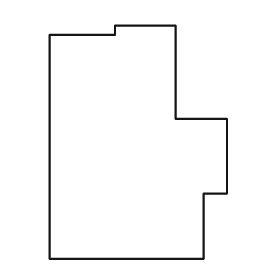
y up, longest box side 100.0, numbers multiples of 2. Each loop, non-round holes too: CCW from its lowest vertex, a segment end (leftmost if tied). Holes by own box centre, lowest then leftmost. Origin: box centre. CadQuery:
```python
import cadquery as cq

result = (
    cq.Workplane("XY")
    .moveTo(-38.0, -50.0)
    .lineTo(28.0, -50.0)
    .lineTo(28.0, -22.0)
    .lineTo(38.0, -22.0)
    .lineTo(38.0, 10.0)
    .lineTo(16.0, 10.0)
    .lineTo(16.0, 50.0)
    .lineTo(-10.0, 50.0)
    .lineTo(-10.0, 46.0)
    .lineTo(-38.0, 46.0)
    .close()
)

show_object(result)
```